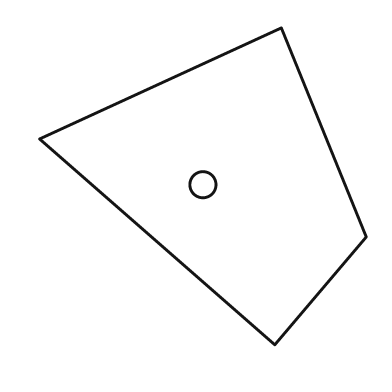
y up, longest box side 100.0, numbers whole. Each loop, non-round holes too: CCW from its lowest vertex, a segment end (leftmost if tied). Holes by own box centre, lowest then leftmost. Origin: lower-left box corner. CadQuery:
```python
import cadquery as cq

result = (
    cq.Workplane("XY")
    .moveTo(72.0, 0.0)
    .lineTo(100.0, 33.0)
    .lineTo(74.0, 97.0)
    .lineTo(0.0, 63.0)
    .close()
    .moveTo(50.0, 49.0)
    .circle(4.0)
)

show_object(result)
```